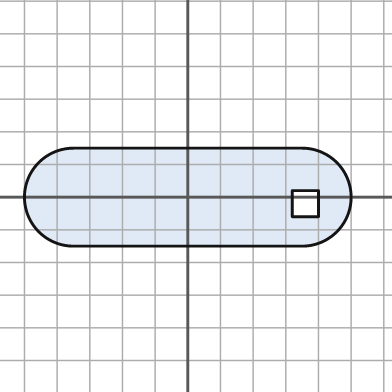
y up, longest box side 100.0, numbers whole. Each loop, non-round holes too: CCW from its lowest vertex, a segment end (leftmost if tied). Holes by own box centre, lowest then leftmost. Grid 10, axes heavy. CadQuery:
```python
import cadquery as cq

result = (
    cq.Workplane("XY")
    .moveTo(-35.0, -15.0)
    .lineTo(35.0, -15.0)
    .threePointArc((50.0, 0.0), (35.0, 15.0))
    .lineTo(-35.0, 15.0)
    .threePointArc((-50.0, 0.0), (-35.0, -15.0))
    .close()
    .moveTo(32.0, -6.0)
    .lineTo(40.0, -6.0)
    .lineTo(40.0, 2.0)
    .lineTo(32.0, 2.0)
    .close()
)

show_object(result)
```